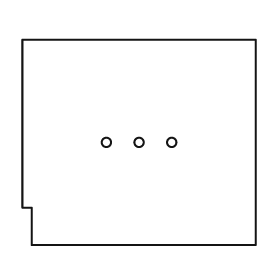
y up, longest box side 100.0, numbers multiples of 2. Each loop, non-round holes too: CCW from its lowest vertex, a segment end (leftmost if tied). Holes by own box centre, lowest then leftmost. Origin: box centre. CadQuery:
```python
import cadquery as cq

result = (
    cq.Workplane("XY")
    .moveTo(-46.0, -44.0)
    .lineTo(50.0, -44.0)
    .lineTo(50.0, 44.0)
    .lineTo(-50.0, 44.0)
    .lineTo(-50.0, -28.0)
    .lineTo(-46.0, -28.0)
    .close()
    .moveTo(-14.0, 0.0)
    .circle(2.0)
    .moveTo(0.0, 0.0)
    .circle(2.0)
    .moveTo(14.0, 0.0)
    .circle(2.0)
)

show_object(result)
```